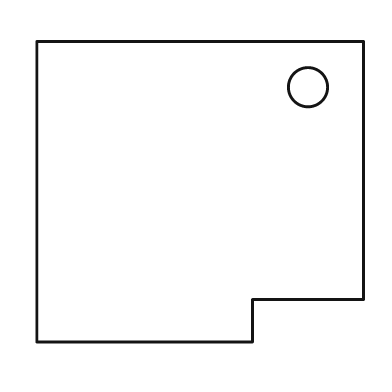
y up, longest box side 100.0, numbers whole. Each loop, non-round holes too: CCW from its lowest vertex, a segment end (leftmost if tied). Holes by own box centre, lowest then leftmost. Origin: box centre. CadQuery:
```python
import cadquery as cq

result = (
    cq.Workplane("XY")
    .moveTo(-50.0, -46.0)
    .lineTo(16.0, -46.0)
    .lineTo(16.0, -33.0)
    .lineTo(50.0, -33.0)
    .lineTo(50.0, 46.0)
    .lineTo(-50.0, 46.0)
    .close()
    .moveTo(33.0, 32.0)
    .circle(6.0)
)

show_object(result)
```